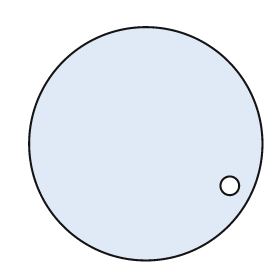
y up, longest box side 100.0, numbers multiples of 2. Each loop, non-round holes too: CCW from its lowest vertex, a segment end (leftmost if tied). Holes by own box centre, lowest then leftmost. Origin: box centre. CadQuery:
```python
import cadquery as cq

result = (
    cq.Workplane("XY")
    .moveTo(0.0, 0.0)
    .circle(50.0)
    .moveTo(36.0, -18.0)
    .circle(4.0)
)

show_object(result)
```